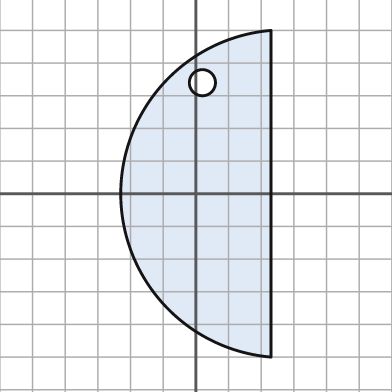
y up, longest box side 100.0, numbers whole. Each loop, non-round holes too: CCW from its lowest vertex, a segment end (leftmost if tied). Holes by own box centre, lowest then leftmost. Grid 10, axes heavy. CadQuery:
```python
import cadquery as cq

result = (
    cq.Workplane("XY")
    .moveTo(23.0, -50.0)
    .lineTo(23.0, 50.0)
    .threePointArc((-23.0, 0.0), (23.0, -50.0))
    .close()
    .moveTo(2.0, 34.0)
    .circle(4.0)
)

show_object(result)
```